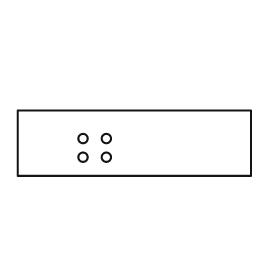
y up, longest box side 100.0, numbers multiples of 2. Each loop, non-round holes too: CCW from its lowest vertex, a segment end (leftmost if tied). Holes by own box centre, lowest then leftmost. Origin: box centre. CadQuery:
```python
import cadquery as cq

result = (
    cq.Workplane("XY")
    .moveTo(-50.0, -14.0)
    .lineTo(50.0, -14.0)
    .lineTo(50.0, 14.0)
    .lineTo(-50.0, 14.0)
    .close()
    .moveTo(-22.0, -6.0)
    .circle(2.0)
    .moveTo(-12.0, -6.0)
    .circle(2.0)
    .moveTo(-22.0, 2.0)
    .circle(2.0)
    .moveTo(-12.0, 2.0)
    .circle(2.0)
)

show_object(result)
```